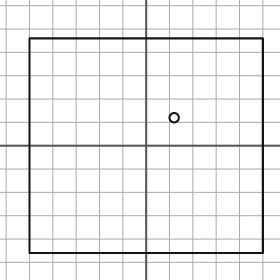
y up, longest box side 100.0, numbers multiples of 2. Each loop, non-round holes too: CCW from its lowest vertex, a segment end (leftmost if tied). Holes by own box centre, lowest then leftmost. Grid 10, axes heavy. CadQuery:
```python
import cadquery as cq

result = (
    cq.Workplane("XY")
    .moveTo(-50.0, -46.0)
    .lineTo(50.0, -46.0)
    .lineTo(50.0, 46.0)
    .lineTo(-50.0, 46.0)
    .close()
    .moveTo(12.0, 12.0)
    .circle(2.0)
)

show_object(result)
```